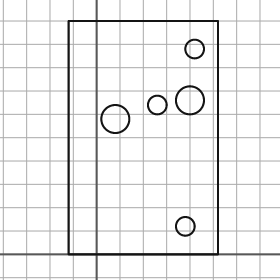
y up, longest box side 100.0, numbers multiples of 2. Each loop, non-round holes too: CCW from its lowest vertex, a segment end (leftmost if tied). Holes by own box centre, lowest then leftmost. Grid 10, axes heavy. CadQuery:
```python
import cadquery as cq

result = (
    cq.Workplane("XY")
    .moveTo(-12.0, 0.0)
    .lineTo(52.0, 0.0)
    .lineTo(52.0, 100.0)
    .lineTo(-12.0, 100.0)
    .close()
    .moveTo(38.0, 12.0)
    .circle(4.0)
    .moveTo(8.0, 58.0)
    .circle(6.0)
    .moveTo(26.0, 64.0)
    .circle(4.0)
    .moveTo(40.0, 66.0)
    .circle(6.0)
    .moveTo(42.0, 88.0)
    .circle(4.0)
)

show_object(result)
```